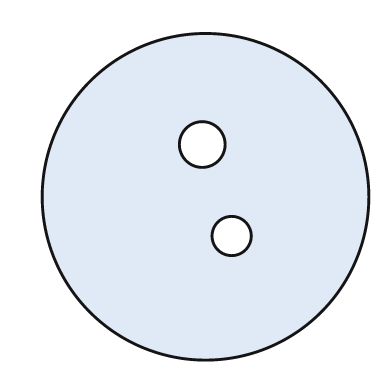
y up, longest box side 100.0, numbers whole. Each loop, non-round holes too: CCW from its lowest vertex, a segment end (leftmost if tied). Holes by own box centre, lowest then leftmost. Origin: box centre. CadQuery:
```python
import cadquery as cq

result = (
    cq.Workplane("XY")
    .moveTo(0.0, 0.0)
    .circle(50.0)
    .moveTo(8.0, -12.0)
    .circle(6.0)
    .moveTo(-1.0, 16.0)
    .circle(7.0)
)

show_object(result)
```